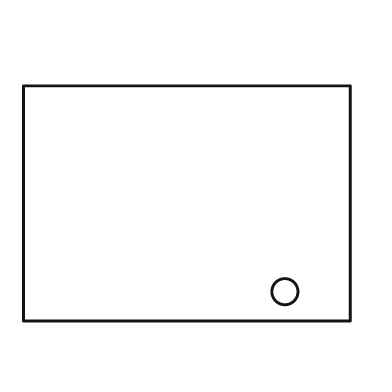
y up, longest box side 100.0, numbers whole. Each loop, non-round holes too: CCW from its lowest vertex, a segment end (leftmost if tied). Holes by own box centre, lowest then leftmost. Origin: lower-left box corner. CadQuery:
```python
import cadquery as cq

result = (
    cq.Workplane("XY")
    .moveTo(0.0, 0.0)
    .lineTo(100.0, 0.0)
    .lineTo(100.0, 72.0)
    .lineTo(0.0, 72.0)
    .close()
    .moveTo(80.0, 9.0)
    .circle(4.0)
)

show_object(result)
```